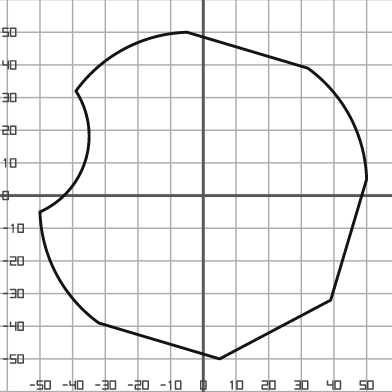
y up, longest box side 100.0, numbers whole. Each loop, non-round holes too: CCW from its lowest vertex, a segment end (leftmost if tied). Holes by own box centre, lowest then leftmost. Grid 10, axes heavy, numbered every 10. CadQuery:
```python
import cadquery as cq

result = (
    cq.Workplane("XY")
    .moveTo(5.0, -50.0)
    .lineTo(39.0, -32.0)
    .lineTo(50.0, 5.0)
    .threePointArc((45.0, 24.0), (32.0, 39.0))
    .lineTo(-5.0, 50.0)
    .threePointArc((-24.0, 45.0), (-39.0, 32.0))
    .threePointArc((-36.0, 11.0), (-50.0, -5.0))
    .threePointArc((-45.0, -24.0), (-32.0, -39.0))
    .close()
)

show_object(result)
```